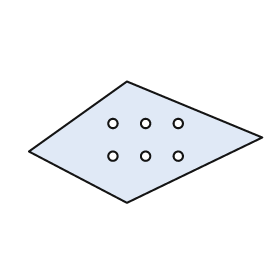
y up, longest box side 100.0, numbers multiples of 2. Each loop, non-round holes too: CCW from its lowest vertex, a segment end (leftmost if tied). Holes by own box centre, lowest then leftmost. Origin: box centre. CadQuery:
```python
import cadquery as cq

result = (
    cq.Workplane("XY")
    .moveTo(-8.0, -26.0)
    .lineTo(50.0, 2.0)
    .lineTo(-8.0, 26.0)
    .lineTo(-50.0, -4.0)
    .close()
    .moveTo(-14.0, -6.0)
    .circle(2.0)
    .moveTo(0.0, -6.0)
    .circle(2.0)
    .moveTo(14.0, -6.0)
    .circle(2.0)
    .moveTo(-14.0, 8.0)
    .circle(2.0)
    .moveTo(0.0, 8.0)
    .circle(2.0)
    .moveTo(14.0, 8.0)
    .circle(2.0)
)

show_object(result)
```